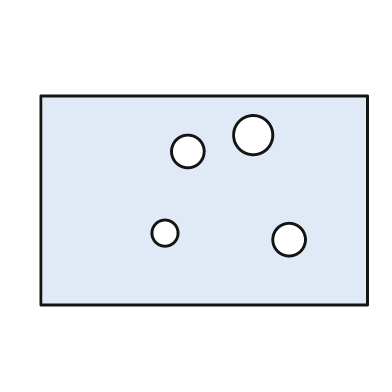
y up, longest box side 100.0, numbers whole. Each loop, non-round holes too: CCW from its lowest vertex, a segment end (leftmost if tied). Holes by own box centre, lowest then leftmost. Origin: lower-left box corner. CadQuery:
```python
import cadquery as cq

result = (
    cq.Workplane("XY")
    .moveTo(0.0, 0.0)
    .lineTo(100.0, 0.0)
    .lineTo(100.0, 64.0)
    .lineTo(0.0, 64.0)
    .close()
    .moveTo(76.0, 20.0)
    .circle(5.0)
    .moveTo(38.0, 22.0)
    .circle(4.0)
    .moveTo(45.0, 47.0)
    .circle(5.0)
    .moveTo(65.0, 52.0)
    .circle(6.0)
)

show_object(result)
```